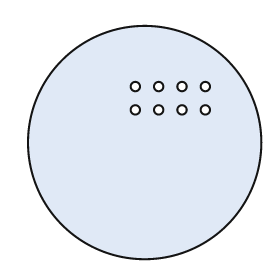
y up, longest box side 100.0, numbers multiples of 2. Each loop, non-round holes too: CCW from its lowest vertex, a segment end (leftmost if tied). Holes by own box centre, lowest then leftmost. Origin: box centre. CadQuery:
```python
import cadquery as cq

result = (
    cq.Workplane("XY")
    .moveTo(0.0, 0.0)
    .circle(50.0)
    .moveTo(-4.0, 14.0)
    .circle(2.0)
    .moveTo(6.0, 14.0)
    .circle(2.0)
    .moveTo(16.0, 14.0)
    .circle(2.0)
    .moveTo(26.0, 14.0)
    .circle(2.0)
    .moveTo(-4.0, 24.0)
    .circle(2.0)
    .moveTo(6.0, 24.0)
    .circle(2.0)
    .moveTo(16.0, 24.0)
    .circle(2.0)
    .moveTo(26.0, 24.0)
    .circle(2.0)
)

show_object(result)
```